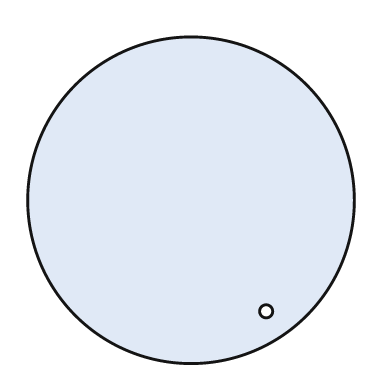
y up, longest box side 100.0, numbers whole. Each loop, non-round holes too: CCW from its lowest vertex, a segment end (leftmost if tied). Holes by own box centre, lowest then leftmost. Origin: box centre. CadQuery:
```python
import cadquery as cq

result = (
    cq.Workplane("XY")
    .moveTo(0.0, 0.0)
    .circle(50.0)
    .moveTo(23.0, -34.0)
    .circle(2.0)
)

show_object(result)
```